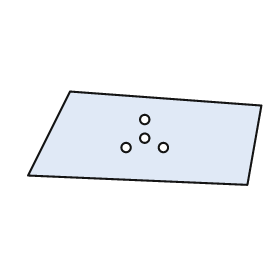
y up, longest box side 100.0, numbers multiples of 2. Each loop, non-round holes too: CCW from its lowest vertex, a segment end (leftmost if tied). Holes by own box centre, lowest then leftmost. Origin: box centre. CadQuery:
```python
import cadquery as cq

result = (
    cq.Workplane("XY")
    .moveTo(44.0, -20.0)
    .lineTo(50.0, 14.0)
    .lineTo(-32.0, 20.0)
    .lineTo(-50.0, -16.0)
    .close()
    .moveTo(-8.0, -4.0)
    .circle(2.0)
    .moveTo(8.0, -4.0)
    .circle(2.0)
    .moveTo(0.0, 0.0)
    .circle(2.0)
    .moveTo(0.0, 8.0)
    .circle(2.0)
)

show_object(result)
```